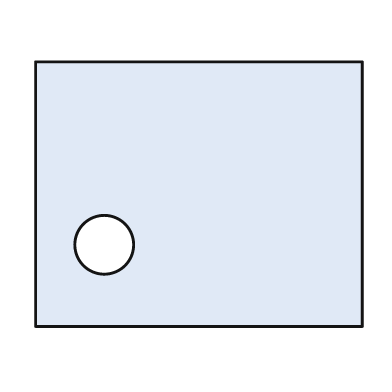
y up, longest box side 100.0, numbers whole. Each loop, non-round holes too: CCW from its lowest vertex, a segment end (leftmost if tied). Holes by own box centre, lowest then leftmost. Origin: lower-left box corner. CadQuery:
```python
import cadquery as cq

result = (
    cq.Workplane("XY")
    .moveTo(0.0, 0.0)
    .lineTo(100.0, 0.0)
    .lineTo(100.0, 81.0)
    .lineTo(0.0, 81.0)
    .close()
    .moveTo(21.0, 25.0)
    .circle(9.0)
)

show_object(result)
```